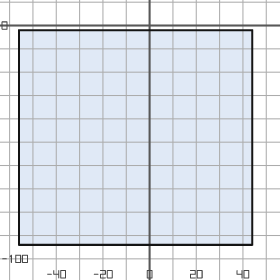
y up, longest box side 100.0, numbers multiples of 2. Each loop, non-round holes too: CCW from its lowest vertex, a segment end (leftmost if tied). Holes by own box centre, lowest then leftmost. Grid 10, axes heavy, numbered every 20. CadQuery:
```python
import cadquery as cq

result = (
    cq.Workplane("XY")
    .moveTo(-56.0, -94.0)
    .lineTo(44.0, -94.0)
    .lineTo(44.0, -2.0)
    .lineTo(-56.0, -2.0)
    .close()
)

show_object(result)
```